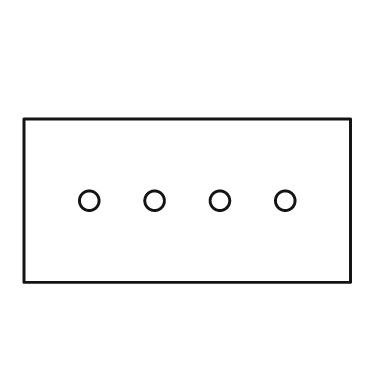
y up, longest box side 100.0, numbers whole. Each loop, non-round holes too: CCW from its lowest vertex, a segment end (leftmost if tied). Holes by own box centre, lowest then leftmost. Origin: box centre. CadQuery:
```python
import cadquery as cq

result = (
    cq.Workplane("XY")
    .moveTo(-50.0, -25.0)
    .lineTo(50.0, -25.0)
    .lineTo(50.0, 25.0)
    .lineTo(-50.0, 25.0)
    .close()
    .moveTo(-30.0, 0.0)
    .circle(3.0)
    .moveTo(-10.0, 0.0)
    .circle(3.0)
    .moveTo(10.0, 0.0)
    .circle(3.0)
    .moveTo(30.0, 0.0)
    .circle(3.0)
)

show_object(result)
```